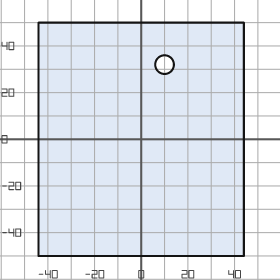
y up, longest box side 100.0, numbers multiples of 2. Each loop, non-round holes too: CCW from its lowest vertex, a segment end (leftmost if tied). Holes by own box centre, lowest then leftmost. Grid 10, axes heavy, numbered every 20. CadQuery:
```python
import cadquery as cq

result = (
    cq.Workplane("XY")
    .moveTo(-44.0, -50.0)
    .lineTo(44.0, -50.0)
    .lineTo(44.0, 50.0)
    .lineTo(-44.0, 50.0)
    .close()
    .moveTo(10.0, 32.0)
    .circle(4.0)
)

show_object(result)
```